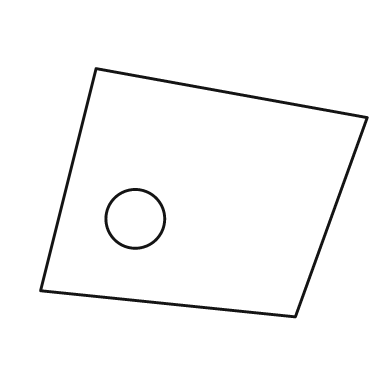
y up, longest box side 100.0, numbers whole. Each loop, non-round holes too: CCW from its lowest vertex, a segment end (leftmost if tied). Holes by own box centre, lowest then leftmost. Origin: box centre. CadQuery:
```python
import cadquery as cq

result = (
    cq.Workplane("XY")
    .moveTo(28.0, -38.0)
    .lineTo(50.0, 23.0)
    .lineTo(-33.0, 38.0)
    .lineTo(-50.0, -30.0)
    .close()
    .moveTo(-21.0, -8.0)
    .circle(9.0)
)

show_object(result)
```